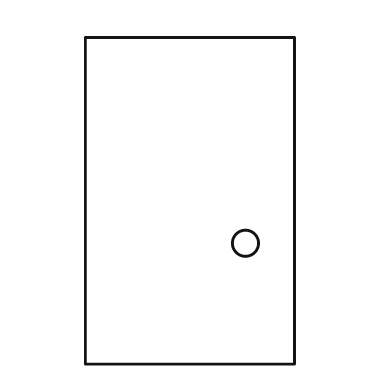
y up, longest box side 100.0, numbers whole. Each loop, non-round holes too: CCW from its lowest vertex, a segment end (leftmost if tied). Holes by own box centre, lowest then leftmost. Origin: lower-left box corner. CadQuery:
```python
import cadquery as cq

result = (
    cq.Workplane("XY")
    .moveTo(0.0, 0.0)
    .lineTo(64.0, 0.0)
    .lineTo(64.0, 100.0)
    .lineTo(0.0, 100.0)
    .close()
    .moveTo(49.0, 37.0)
    .circle(4.0)
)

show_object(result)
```